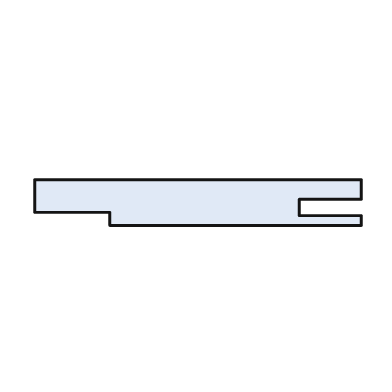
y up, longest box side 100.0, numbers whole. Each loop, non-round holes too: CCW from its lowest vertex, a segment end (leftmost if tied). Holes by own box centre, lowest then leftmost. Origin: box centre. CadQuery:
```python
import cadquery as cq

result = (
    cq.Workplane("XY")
    .moveTo(-27.0, -7.0)
    .lineTo(50.0, -7.0)
    .lineTo(50.0, -4.0)
    .lineTo(31.0, -4.0)
    .lineTo(31.0, 1.0)
    .lineTo(50.0, 1.0)
    .lineTo(50.0, 7.0)
    .lineTo(-50.0, 7.0)
    .lineTo(-50.0, -3.0)
    .lineTo(-27.0, -3.0)
    .close()
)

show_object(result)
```